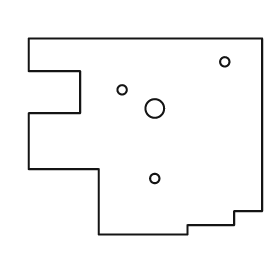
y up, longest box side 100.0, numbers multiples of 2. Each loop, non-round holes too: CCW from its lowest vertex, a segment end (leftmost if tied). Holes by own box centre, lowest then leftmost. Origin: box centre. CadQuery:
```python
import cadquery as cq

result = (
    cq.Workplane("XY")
    .moveTo(-20.0, -42.0)
    .lineTo(18.0, -42.0)
    .lineTo(18.0, -38.0)
    .lineTo(38.0, -38.0)
    .lineTo(38.0, -32.0)
    .lineTo(50.0, -32.0)
    .lineTo(50.0, 42.0)
    .lineTo(-50.0, 42.0)
    .lineTo(-50.0, 28.0)
    .lineTo(-28.0, 28.0)
    .lineTo(-28.0, 10.0)
    .lineTo(-50.0, 10.0)
    .lineTo(-50.0, -14.0)
    .lineTo(-20.0, -14.0)
    .close()
    .moveTo(4.0, -18.0)
    .circle(2.0)
    .moveTo(4.0, 12.0)
    .circle(4.0)
    .moveTo(-10.0, 20.0)
    .circle(2.0)
    .moveTo(34.0, 32.0)
    .circle(2.0)
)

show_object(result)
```